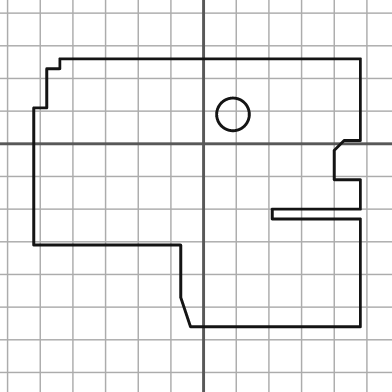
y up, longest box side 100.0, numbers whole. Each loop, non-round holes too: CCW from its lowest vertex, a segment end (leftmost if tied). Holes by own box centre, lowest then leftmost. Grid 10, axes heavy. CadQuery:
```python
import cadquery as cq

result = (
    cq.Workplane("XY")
    .moveTo(-4.0, -56.0)
    .lineTo(48.0, -56.0)
    .lineTo(48.0, -23.0)
    .lineTo(21.0, -23.0)
    .lineTo(21.0, -20.0)
    .lineTo(48.0, -20.0)
    .lineTo(48.0, -11.0)
    .lineTo(40.0, -11.0)
    .lineTo(40.0, -2.0)
    .lineTo(43.0, 1.0)
    .lineTo(48.0, 1.0)
    .lineTo(48.0, 26.0)
    .lineTo(-44.0, 26.0)
    .lineTo(-44.0, 23.0)
    .lineTo(-48.0, 23.0)
    .lineTo(-48.0, 11.0)
    .lineTo(-52.0, 11.0)
    .lineTo(-52.0, -31.0)
    .lineTo(-7.0, -31.0)
    .lineTo(-7.0, -47.0)
    .close()
    .moveTo(9.0, 9.0)
    .circle(5.0)
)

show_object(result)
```